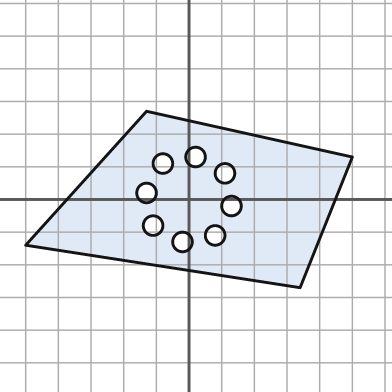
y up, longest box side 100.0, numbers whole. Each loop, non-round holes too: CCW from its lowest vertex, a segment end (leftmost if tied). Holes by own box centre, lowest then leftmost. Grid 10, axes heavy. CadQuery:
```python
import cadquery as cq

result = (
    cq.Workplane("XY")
    .moveTo(34.0, -27.0)
    .lineTo(50.0, 13.0)
    .lineTo(-13.0, 27.0)
    .lineTo(-50.0, -14.0)
    .close()
    .moveTo(-2.0, -13.0)
    .circle(3.0)
    .moveTo(8.0, -11.0)
    .circle(3.0)
    .moveTo(-11.0, -8.0)
    .circle(3.0)
    .moveTo(13.0, -2.0)
    .circle(3.0)
    .moveTo(-13.0, 2.0)
    .circle(3.0)
    .moveTo(11.0, 8.0)
    .circle(3.0)
    .moveTo(-8.0, 11.0)
    .circle(3.0)
    .moveTo(2.0, 13.0)
    .circle(3.0)
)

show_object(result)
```